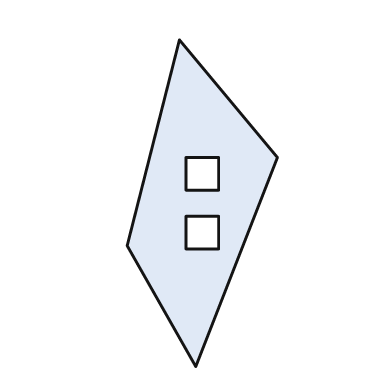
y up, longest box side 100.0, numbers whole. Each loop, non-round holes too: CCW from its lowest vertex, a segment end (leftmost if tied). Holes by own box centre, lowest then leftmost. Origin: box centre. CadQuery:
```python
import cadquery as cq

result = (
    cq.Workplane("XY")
    .moveTo(-2.0, -50.0)
    .lineTo(23.0, 14.0)
    .lineTo(-7.0, 50.0)
    .lineTo(-23.0, -13.0)
    .close()
    .moveTo(-5.0, -14.0)
    .lineTo(5.0, -14.0)
    .lineTo(5.0, -4.0)
    .lineTo(-5.0, -4.0)
    .close()
    .moveTo(-5.0, 4.0)
    .lineTo(5.0, 4.0)
    .lineTo(5.0, 14.0)
    .lineTo(-5.0, 14.0)
    .close()
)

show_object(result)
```